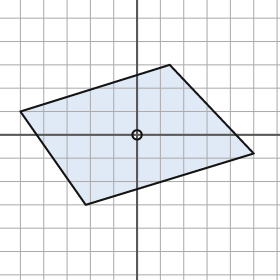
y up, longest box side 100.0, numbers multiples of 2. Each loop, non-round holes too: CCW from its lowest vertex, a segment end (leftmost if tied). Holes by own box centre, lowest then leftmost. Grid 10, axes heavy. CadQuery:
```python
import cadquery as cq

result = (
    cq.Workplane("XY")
    .moveTo(-22.0, -30.0)
    .lineTo(50.0, -8.0)
    .lineTo(14.0, 30.0)
    .lineTo(-50.0, 10.0)
    .close()
    .moveTo(0.0, 0.0)
    .circle(2.0)
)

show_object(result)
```